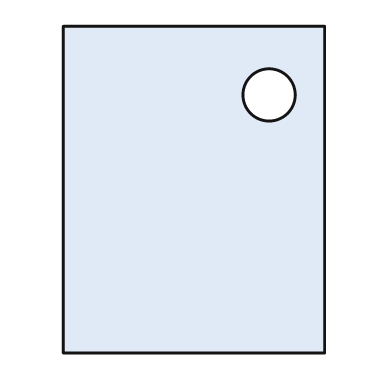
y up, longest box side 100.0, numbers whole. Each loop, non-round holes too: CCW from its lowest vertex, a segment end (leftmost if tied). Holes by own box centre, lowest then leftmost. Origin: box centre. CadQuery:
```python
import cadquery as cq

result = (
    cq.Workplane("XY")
    .moveTo(-40.0, -50.0)
    .lineTo(40.0, -50.0)
    .lineTo(40.0, 50.0)
    .lineTo(-40.0, 50.0)
    .close()
    .moveTo(23.0, 29.0)
    .circle(8.0)
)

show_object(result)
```